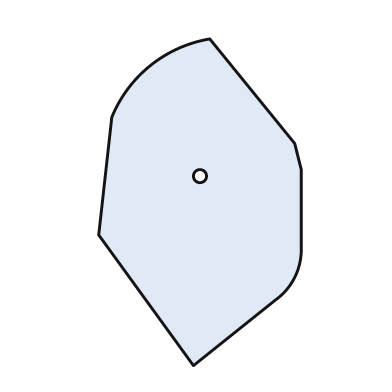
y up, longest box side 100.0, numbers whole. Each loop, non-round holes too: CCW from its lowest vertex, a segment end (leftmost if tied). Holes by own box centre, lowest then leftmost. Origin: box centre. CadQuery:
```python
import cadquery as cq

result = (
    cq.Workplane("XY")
    .moveTo(-2.0, -50.0)
    .lineTo(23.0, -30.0)
    .threePointArc((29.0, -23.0), (31.0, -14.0))
    .lineTo(31.0, 10.0)
    .lineTo(29.0, 18.0)
    .lineTo(3.0, 50.0)
    .threePointArc((-15.0, 42.0), (-27.0, 26.0))
    .lineTo(-31.0, -10.0)
    .close()
    .moveTo(0.0, 8.0)
    .circle(2.0)
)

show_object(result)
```